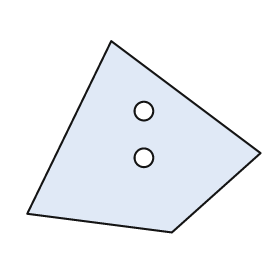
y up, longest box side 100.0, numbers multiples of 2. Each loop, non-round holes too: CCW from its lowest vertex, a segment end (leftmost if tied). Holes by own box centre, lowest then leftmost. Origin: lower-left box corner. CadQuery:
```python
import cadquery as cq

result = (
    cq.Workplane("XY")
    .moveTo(62.0, 0.0)
    .lineTo(100.0, 34.0)
    .lineTo(36.0, 82.0)
    .lineTo(0.0, 8.0)
    .close()
    .moveTo(50.0, 32.0)
    .circle(4.0)
    .moveTo(50.0, 52.0)
    .circle(4.0)
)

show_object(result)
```